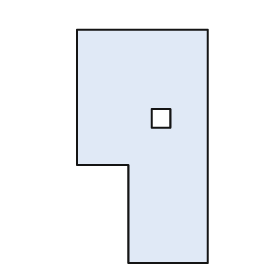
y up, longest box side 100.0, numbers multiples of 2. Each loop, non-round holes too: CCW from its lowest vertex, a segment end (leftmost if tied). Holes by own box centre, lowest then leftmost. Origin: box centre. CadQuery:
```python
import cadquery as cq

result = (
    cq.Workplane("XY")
    .moveTo(-6.0, -50.0)
    .lineTo(28.0, -50.0)
    .lineTo(28.0, 50.0)
    .lineTo(-28.0, 50.0)
    .lineTo(-28.0, -8.0)
    .lineTo(-6.0, -8.0)
    .close()
    .moveTo(4.0, 8.0)
    .lineTo(12.0, 8.0)
    .lineTo(12.0, 16.0)
    .lineTo(4.0, 16.0)
    .close()
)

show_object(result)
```